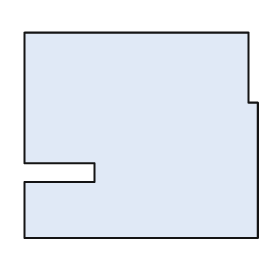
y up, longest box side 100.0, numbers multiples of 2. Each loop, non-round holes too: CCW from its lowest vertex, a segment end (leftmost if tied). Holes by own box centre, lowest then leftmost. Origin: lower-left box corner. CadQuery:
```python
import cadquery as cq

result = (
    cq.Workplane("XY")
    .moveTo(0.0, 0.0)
    .lineTo(100.0, 0.0)
    .lineTo(100.0, 58.0)
    .lineTo(96.0, 58.0)
    .lineTo(96.0, 88.0)
    .lineTo(0.0, 88.0)
    .lineTo(0.0, 32.0)
    .lineTo(30.0, 32.0)
    .lineTo(30.0, 24.0)
    .lineTo(0.0, 24.0)
    .close()
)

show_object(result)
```